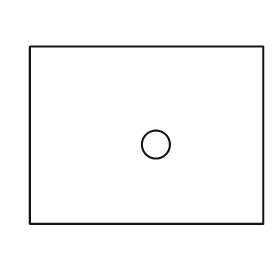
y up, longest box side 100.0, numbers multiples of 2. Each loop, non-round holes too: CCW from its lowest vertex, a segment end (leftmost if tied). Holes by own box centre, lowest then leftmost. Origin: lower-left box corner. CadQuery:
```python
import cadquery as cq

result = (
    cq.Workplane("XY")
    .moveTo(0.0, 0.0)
    .lineTo(100.0, 0.0)
    .lineTo(100.0, 76.0)
    .lineTo(0.0, 76.0)
    .close()
    .moveTo(54.0, 34.0)
    .circle(6.0)
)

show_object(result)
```